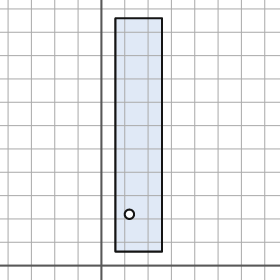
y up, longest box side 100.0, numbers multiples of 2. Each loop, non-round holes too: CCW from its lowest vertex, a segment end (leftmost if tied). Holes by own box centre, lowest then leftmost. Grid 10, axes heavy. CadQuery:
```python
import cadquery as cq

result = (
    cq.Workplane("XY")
    .moveTo(6.0, 6.0)
    .lineTo(26.0, 6.0)
    .lineTo(26.0, 106.0)
    .lineTo(6.0, 106.0)
    .close()
    .moveTo(12.0, 22.0)
    .circle(2.0)
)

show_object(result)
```